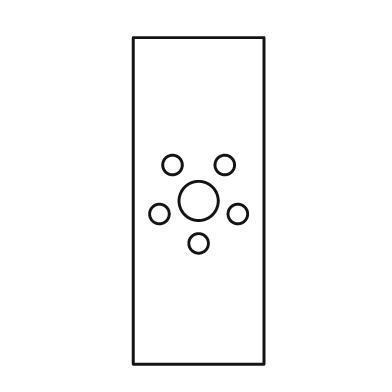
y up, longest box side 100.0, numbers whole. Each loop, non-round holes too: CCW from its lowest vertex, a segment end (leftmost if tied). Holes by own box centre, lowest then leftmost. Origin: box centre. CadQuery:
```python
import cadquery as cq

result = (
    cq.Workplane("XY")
    .moveTo(-20.0, -50.0)
    .lineTo(20.0, -50.0)
    .lineTo(20.0, 50.0)
    .lineTo(-20.0, 50.0)
    .close()
    .moveTo(0.0, -13.0)
    .circle(3.0)
    .moveTo(-12.0, -4.0)
    .circle(3.0)
    .moveTo(12.0, -4.0)
    .circle(3.0)
    .moveTo(0.0, 0.0)
    .circle(6.0)
    .moveTo(-8.0, 11.0)
    .circle(3.0)
    .moveTo(8.0, 11.0)
    .circle(3.0)
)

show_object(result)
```